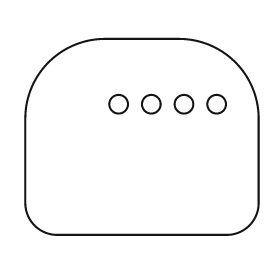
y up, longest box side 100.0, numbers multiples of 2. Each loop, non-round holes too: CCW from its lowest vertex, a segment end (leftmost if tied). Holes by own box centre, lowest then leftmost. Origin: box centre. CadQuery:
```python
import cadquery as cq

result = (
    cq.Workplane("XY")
    .moveTo(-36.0, -42.0)
    .lineTo(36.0, -42.0)
    .threePointArc((46.0, -38.0), (50.0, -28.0))
    .lineTo(50.0, 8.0)
    .threePointArc((40.0, 32.0), (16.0, 42.0))
    .lineTo(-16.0, 42.0)
    .threePointArc((-40.0, 32.0), (-50.0, 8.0))
    .lineTo(-50.0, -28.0)
    .threePointArc((-46.0, -38.0), (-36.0, -42.0))
    .close()
    .moveTo(-10.0, 14.0)
    .circle(4.0)
    .moveTo(4.0, 14.0)
    .circle(4.0)
    .moveTo(18.0, 14.0)
    .circle(4.0)
    .moveTo(32.0, 14.0)
    .circle(4.0)
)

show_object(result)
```